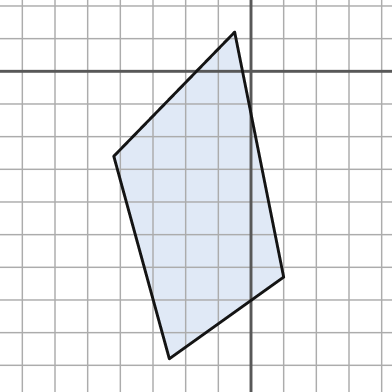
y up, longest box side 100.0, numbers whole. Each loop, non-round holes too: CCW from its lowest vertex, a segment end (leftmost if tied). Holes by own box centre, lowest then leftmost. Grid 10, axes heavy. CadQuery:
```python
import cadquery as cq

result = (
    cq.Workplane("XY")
    .moveTo(-25.0, -88.0)
    .lineTo(10.0, -63.0)
    .lineTo(-5.0, 12.0)
    .lineTo(-42.0, -26.0)
    .close()
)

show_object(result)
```